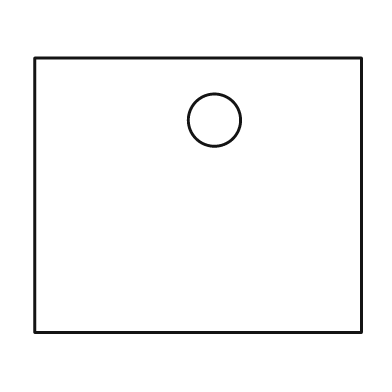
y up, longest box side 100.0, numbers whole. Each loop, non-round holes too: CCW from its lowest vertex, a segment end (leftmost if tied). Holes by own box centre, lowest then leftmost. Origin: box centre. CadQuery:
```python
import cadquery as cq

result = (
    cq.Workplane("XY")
    .moveTo(-50.0, -42.0)
    .lineTo(50.0, -42.0)
    .lineTo(50.0, 42.0)
    .lineTo(-50.0, 42.0)
    .close()
    .moveTo(5.0, 23.0)
    .circle(8.0)
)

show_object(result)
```